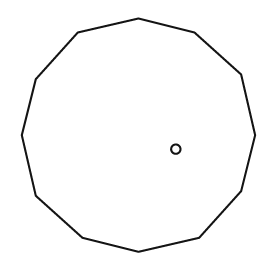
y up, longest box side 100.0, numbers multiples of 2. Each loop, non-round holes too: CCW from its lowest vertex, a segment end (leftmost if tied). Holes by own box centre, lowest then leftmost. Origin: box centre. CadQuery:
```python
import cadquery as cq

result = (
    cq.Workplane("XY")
    .moveTo(0.0, -50.0)
    .lineTo(26.0, -44.0)
    .lineTo(44.0, -24.0)
    .lineTo(50.0, 0.0)
    .lineTo(44.0, 26.0)
    .lineTo(24.0, 44.0)
    .lineTo(0.0, 50.0)
    .lineTo(-26.0, 44.0)
    .lineTo(-44.0, 24.0)
    .lineTo(-50.0, 0.0)
    .lineTo(-44.0, -26.0)
    .lineTo(-24.0, -44.0)
    .close()
    .moveTo(16.0, -6.0)
    .circle(2.0)
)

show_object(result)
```